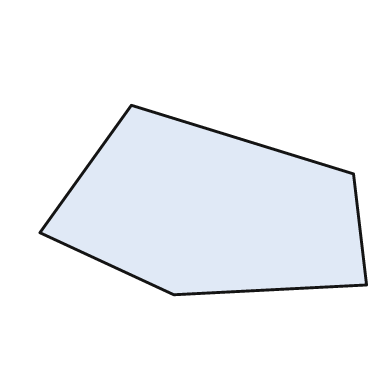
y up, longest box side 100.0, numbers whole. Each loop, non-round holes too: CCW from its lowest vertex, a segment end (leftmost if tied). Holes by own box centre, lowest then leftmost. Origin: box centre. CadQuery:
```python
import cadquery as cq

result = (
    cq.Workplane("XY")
    .moveTo(-9.0, -29.0)
    .lineTo(50.0, -26.0)
    .lineTo(46.0, 8.0)
    .lineTo(-22.0, 29.0)
    .lineTo(-50.0, -10.0)
    .close()
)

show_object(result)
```